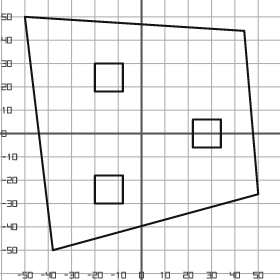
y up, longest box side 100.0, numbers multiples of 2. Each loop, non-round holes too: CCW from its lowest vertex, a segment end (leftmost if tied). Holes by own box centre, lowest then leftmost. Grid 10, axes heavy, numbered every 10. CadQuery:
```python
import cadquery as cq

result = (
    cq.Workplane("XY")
    .moveTo(-38.0, -50.0)
    .lineTo(50.0, -26.0)
    .lineTo(44.0, 44.0)
    .lineTo(-50.0, 50.0)
    .close()
    .moveTo(-20.0, -30.0)
    .lineTo(-8.0, -30.0)
    .lineTo(-8.0, -18.0)
    .lineTo(-20.0, -18.0)
    .close()
    .moveTo(22.0, -6.0)
    .lineTo(34.0, -6.0)
    .lineTo(34.0, 6.0)
    .lineTo(22.0, 6.0)
    .close()
    .moveTo(-20.0, 18.0)
    .lineTo(-8.0, 18.0)
    .lineTo(-8.0, 30.0)
    .lineTo(-20.0, 30.0)
    .close()
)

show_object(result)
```